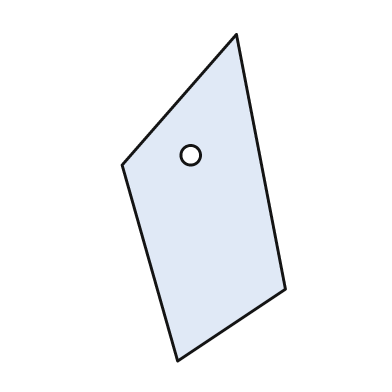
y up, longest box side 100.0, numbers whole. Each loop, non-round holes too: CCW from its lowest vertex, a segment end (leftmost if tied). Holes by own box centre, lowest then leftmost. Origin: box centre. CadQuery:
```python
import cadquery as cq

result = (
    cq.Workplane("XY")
    .moveTo(-8.0, -50.0)
    .lineTo(25.0, -28.0)
    .lineTo(10.0, 50.0)
    .lineTo(-25.0, 10.0)
    .close()
    .moveTo(-4.0, 13.0)
    .circle(3.0)
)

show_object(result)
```